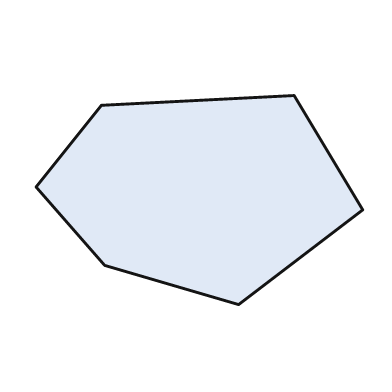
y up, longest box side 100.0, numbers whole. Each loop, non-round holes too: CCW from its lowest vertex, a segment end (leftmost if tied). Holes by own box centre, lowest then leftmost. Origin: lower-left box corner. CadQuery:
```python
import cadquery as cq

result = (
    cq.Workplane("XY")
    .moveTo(62.0, 0.0)
    .lineTo(100.0, 29.0)
    .lineTo(79.0, 64.0)
    .lineTo(20.0, 61.0)
    .lineTo(0.0, 36.0)
    .lineTo(21.0, 12.0)
    .close()
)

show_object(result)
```